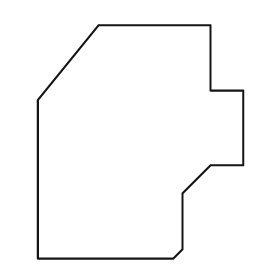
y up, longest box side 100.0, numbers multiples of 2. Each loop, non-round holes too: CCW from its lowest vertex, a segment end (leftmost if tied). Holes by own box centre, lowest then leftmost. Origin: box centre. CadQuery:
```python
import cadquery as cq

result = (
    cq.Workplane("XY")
    .moveTo(-44.0, -50.0)
    .lineTo(14.0, -50.0)
    .lineTo(18.0, -46.0)
    .lineTo(18.0, -22.0)
    .lineTo(30.0, -10.0)
    .lineTo(44.0, -10.0)
    .lineTo(44.0, 22.0)
    .lineTo(30.0, 22.0)
    .lineTo(30.0, 50.0)
    .lineTo(-18.0, 50.0)
    .lineTo(-44.0, 18.0)
    .close()
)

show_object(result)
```